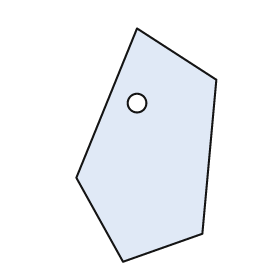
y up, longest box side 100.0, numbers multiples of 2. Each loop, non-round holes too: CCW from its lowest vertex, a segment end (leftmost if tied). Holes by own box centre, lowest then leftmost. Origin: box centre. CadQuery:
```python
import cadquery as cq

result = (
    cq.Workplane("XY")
    .moveTo(-10.0, -50.0)
    .lineTo(24.0, -38.0)
    .lineTo(30.0, 28.0)
    .lineTo(-4.0, 50.0)
    .lineTo(-30.0, -14.0)
    .close()
    .moveTo(-4.0, 18.0)
    .circle(4.0)
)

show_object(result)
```